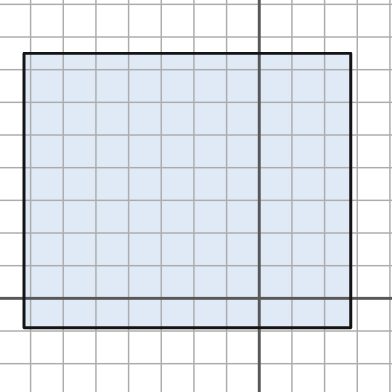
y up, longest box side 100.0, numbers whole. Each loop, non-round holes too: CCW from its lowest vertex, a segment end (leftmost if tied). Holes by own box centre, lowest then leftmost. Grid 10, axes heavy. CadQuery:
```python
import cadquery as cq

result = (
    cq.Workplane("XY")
    .moveTo(-72.0, -9.0)
    .lineTo(28.0, -9.0)
    .lineTo(28.0, 75.0)
    .lineTo(-72.0, 75.0)
    .close()
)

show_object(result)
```